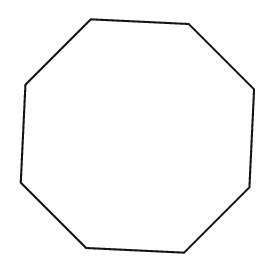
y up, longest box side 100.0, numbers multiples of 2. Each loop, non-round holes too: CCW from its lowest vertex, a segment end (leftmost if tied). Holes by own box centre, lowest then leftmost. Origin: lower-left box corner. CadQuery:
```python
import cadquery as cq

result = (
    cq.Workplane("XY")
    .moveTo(70.0, 0.0)
    .lineTo(98.0, 28.0)
    .lineTo(100.0, 70.0)
    .lineTo(72.0, 98.0)
    .lineTo(30.0, 100.0)
    .lineTo(2.0, 72.0)
    .lineTo(0.0, 30.0)
    .lineTo(28.0, 2.0)
    .close()
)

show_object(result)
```